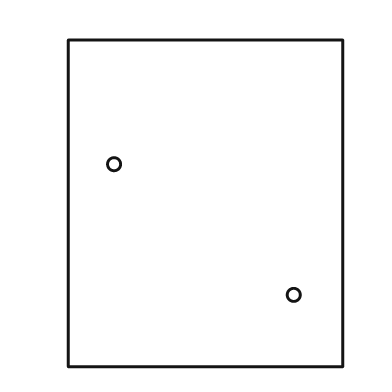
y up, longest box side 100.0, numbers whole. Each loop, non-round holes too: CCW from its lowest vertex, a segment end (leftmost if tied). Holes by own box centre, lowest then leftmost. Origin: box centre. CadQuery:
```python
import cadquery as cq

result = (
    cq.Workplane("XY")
    .moveTo(-42.0, -50.0)
    .lineTo(42.0, -50.0)
    .lineTo(42.0, 50.0)
    .lineTo(-42.0, 50.0)
    .close()
    .moveTo(27.0, -28.0)
    .circle(2.0)
    .moveTo(-28.0, 12.0)
    .circle(2.0)
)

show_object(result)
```